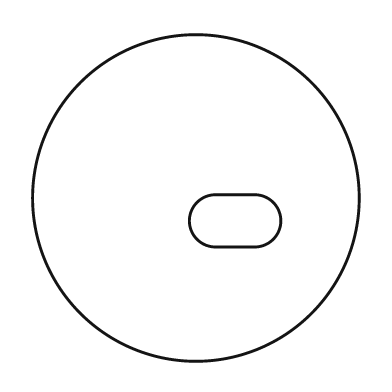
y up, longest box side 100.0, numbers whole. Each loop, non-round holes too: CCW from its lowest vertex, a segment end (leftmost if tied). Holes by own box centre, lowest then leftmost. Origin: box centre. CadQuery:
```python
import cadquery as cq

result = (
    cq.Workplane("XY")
    .moveTo(0.0, 0.0)
    .circle(50.0)
    .moveTo(6.0, -15.0)
    .lineTo(18.0, -15.0)
    .threePointArc((26.0, -7.0), (18.0, 1.0))
    .lineTo(6.0, 1.0)
    .threePointArc((-2.0, -7.0), (6.0, -15.0))
    .close()
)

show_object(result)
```